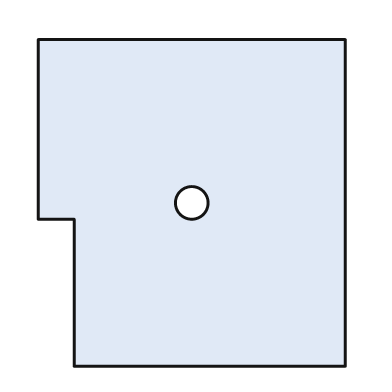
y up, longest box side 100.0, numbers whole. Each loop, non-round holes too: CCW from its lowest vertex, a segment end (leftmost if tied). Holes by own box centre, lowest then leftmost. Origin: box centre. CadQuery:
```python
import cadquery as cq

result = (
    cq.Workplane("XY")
    .moveTo(-36.0, -50.0)
    .lineTo(47.0, -50.0)
    .lineTo(47.0, 50.0)
    .lineTo(-47.0, 50.0)
    .lineTo(-47.0, -5.0)
    .lineTo(-36.0, -5.0)
    .close()
    .moveTo(0.0, 0.0)
    .circle(5.0)
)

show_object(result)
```